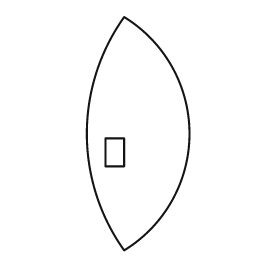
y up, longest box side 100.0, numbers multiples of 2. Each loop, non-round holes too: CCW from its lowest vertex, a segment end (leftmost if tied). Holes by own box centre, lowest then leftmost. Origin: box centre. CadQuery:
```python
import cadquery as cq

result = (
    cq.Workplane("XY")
    .moveTo(-6.0, -50.0)
    .threePointArc((22.0, 0.0), (-6.0, 50.0))
    .threePointArc((-22.0, 0.0), (-6.0, -50.0))
    .close()
    .moveTo(-14.0, -14.0)
    .lineTo(-6.0, -14.0)
    .lineTo(-6.0, -2.0)
    .lineTo(-14.0, -2.0)
    .close()
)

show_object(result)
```